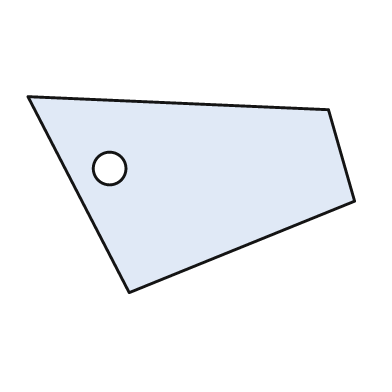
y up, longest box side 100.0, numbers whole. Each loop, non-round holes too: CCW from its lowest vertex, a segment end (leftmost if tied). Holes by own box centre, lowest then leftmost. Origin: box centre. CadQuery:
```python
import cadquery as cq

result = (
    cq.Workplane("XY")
    .moveTo(-19.0, -30.0)
    .lineTo(50.0, -2.0)
    .lineTo(42.0, 26.0)
    .lineTo(-50.0, 30.0)
    .close()
    .moveTo(-25.0, 8.0)
    .circle(5.0)
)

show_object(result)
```